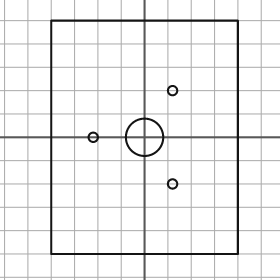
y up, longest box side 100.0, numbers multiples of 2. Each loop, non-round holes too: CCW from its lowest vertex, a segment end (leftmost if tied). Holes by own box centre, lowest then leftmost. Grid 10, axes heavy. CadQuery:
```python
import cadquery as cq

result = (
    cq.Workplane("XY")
    .moveTo(-40.0, -50.0)
    .lineTo(40.0, -50.0)
    .lineTo(40.0, 50.0)
    .lineTo(-40.0, 50.0)
    .close()
    .moveTo(12.0, -20.0)
    .circle(2.0)
    .moveTo(-22.0, 0.0)
    .circle(2.0)
    .moveTo(0.0, 0.0)
    .circle(8.0)
    .moveTo(12.0, 20.0)
    .circle(2.0)
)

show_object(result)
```